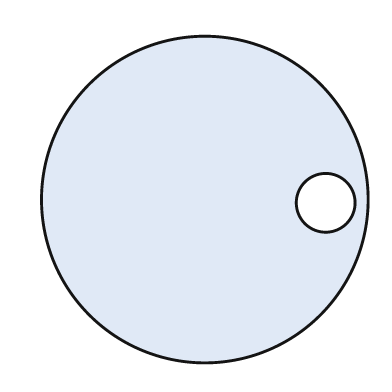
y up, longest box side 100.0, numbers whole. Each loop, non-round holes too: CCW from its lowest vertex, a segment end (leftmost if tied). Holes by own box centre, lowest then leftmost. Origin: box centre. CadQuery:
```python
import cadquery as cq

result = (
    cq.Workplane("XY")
    .moveTo(0.0, 0.0)
    .circle(50.0)
    .moveTo(37.0, -1.0)
    .circle(9.0)
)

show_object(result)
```